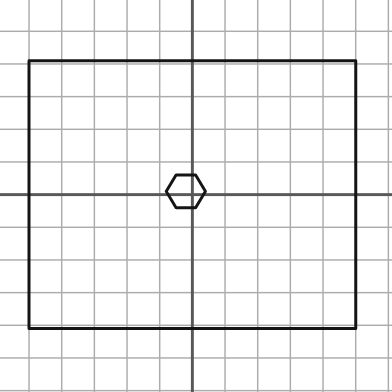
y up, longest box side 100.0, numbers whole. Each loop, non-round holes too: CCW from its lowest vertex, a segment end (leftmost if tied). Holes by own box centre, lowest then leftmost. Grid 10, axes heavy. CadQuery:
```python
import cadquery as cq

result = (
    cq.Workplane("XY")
    .moveTo(-50.0, -41.0)
    .lineTo(50.0, -41.0)
    .lineTo(50.0, 41.0)
    .lineTo(-50.0, 41.0)
    .close()
    .moveTo(-5.0, -4.0)
    .lineTo(1.0, -4.0)
    .lineTo(4.0, 1.0)
    .lineTo(1.0, 6.0)
    .lineTo(-5.0, 6.0)
    .lineTo(-8.0, 1.0)
    .close()
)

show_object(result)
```